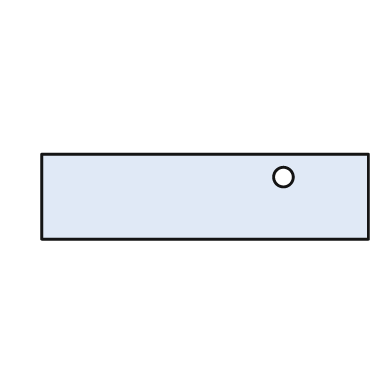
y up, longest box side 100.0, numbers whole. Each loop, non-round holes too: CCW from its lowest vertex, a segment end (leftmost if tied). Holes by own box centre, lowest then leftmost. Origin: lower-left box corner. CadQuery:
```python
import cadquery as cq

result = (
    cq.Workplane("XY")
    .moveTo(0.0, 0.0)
    .lineTo(100.0, 0.0)
    .lineTo(100.0, 26.0)
    .lineTo(0.0, 26.0)
    .close()
    .moveTo(74.0, 19.0)
    .circle(3.0)
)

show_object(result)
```